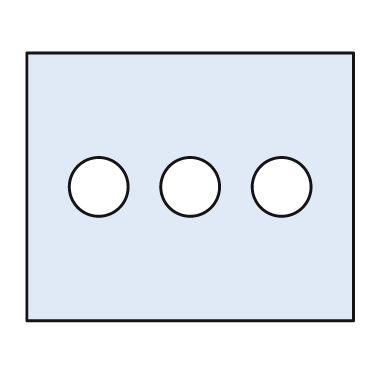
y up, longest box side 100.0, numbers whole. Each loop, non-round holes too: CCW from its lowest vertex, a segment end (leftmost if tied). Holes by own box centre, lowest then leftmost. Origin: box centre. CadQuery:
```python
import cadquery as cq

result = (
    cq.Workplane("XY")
    .moveTo(-50.0, -41.0)
    .lineTo(50.0, -41.0)
    .lineTo(50.0, 41.0)
    .lineTo(-50.0, 41.0)
    .close()
    .moveTo(-28.0, 0.0)
    .circle(9.0)
    .moveTo(0.0, 0.0)
    .circle(9.0)
    .moveTo(28.0, 0.0)
    .circle(9.0)
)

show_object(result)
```